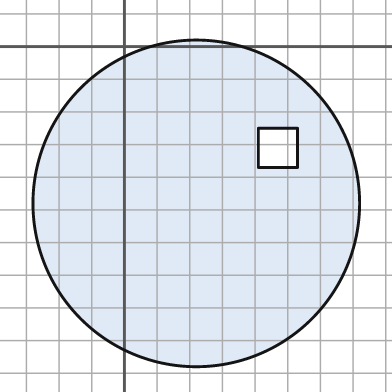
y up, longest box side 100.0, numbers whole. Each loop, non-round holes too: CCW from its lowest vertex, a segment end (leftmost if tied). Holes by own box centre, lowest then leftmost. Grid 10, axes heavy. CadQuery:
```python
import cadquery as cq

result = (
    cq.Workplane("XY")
    .moveTo(22.0, -48.0)
    .circle(50.0)
    .moveTo(41.0, -37.0)
    .lineTo(53.0, -37.0)
    .lineTo(53.0, -25.0)
    .lineTo(41.0, -25.0)
    .close()
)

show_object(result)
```